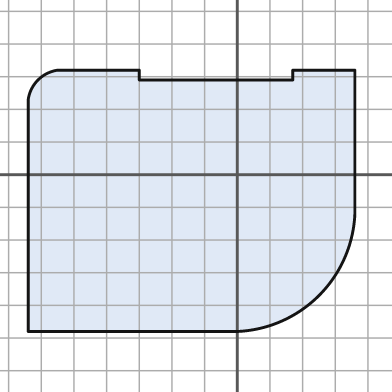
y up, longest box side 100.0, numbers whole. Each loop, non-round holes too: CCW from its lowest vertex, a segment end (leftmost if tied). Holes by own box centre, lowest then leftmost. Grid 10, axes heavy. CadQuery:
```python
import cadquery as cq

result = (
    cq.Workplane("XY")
    .moveTo(-64.0, -48.0)
    .lineTo(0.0, -48.0)
    .threePointArc((25.0, -37.0), (36.0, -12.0))
    .lineTo(36.0, 32.0)
    .lineTo(17.0, 32.0)
    .lineTo(17.0, 29.0)
    .lineTo(-30.0, 29.0)
    .lineTo(-30.0, 32.0)
    .lineTo(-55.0, 32.0)
    .threePointArc((-61.0, 29.0), (-64.0, 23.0))
    .close()
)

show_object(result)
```